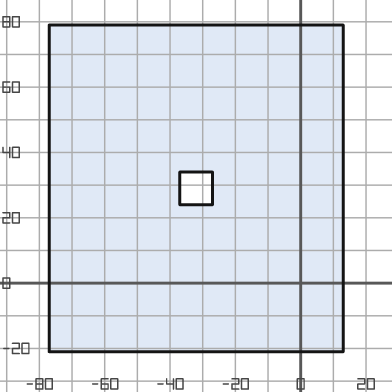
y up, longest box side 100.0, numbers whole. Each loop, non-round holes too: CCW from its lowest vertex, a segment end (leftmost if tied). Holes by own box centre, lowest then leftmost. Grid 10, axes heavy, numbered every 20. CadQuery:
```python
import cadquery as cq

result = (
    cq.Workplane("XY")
    .moveTo(-77.0, -21.0)
    .lineTo(13.0, -21.0)
    .lineTo(13.0, 79.0)
    .lineTo(-77.0, 79.0)
    .close()
    .moveTo(-37.0, 24.0)
    .lineTo(-27.0, 24.0)
    .lineTo(-27.0, 34.0)
    .lineTo(-37.0, 34.0)
    .close()
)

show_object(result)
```